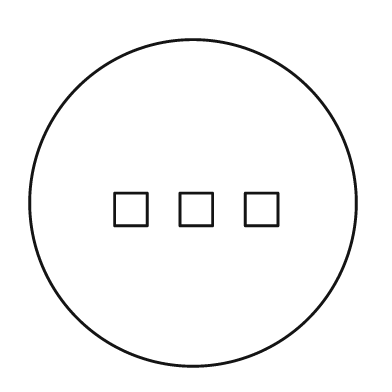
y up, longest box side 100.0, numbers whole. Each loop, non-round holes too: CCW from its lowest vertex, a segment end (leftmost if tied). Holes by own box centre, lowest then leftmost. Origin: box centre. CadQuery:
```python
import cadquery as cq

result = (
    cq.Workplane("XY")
    .moveTo(0.0, 0.0)
    .circle(50.0)
    .moveTo(-24.0, -7.0)
    .lineTo(-14.0, -7.0)
    .lineTo(-14.0, 3.0)
    .lineTo(-24.0, 3.0)
    .close()
    .moveTo(-4.0, -7.0)
    .lineTo(6.0, -7.0)
    .lineTo(6.0, 3.0)
    .lineTo(-4.0, 3.0)
    .close()
    .moveTo(16.0, -7.0)
    .lineTo(26.0, -7.0)
    .lineTo(26.0, 3.0)
    .lineTo(16.0, 3.0)
    .close()
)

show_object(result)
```